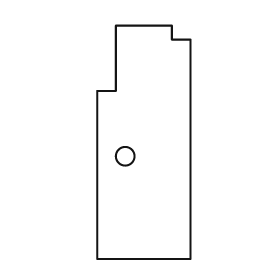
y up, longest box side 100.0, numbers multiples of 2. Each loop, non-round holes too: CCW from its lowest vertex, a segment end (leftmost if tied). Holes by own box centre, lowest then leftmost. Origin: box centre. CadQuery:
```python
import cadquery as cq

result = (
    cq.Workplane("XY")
    .moveTo(-20.0, -50.0)
    .lineTo(20.0, -50.0)
    .lineTo(20.0, 44.0)
    .lineTo(12.0, 44.0)
    .lineTo(12.0, 50.0)
    .lineTo(-12.0, 50.0)
    .lineTo(-12.0, 22.0)
    .lineTo(-20.0, 22.0)
    .close()
    .moveTo(-8.0, -6.0)
    .circle(4.0)
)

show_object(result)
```